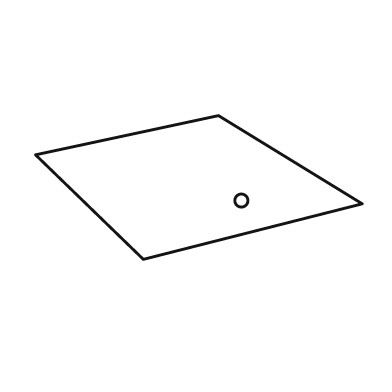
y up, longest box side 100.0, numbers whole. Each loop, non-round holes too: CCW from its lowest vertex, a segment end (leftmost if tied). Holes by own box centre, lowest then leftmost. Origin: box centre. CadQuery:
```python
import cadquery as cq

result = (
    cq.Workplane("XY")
    .moveTo(-17.0, -22.0)
    .lineTo(50.0, -5.0)
    .lineTo(6.0, 22.0)
    .lineTo(-50.0, 10.0)
    .close()
    .moveTo(13.0, -4.0)
    .circle(2.0)
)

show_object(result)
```